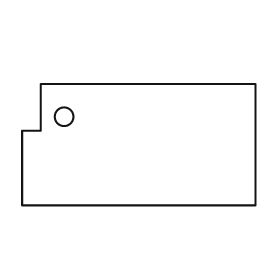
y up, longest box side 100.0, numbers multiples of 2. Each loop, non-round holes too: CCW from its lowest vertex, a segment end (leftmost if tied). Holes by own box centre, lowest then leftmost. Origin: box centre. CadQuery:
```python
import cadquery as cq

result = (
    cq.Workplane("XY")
    .moveTo(-50.0, -26.0)
    .lineTo(50.0, -26.0)
    .lineTo(50.0, 26.0)
    .lineTo(-42.0, 26.0)
    .lineTo(-42.0, 6.0)
    .lineTo(-50.0, 6.0)
    .close()
    .moveTo(-32.0, 12.0)
    .circle(4.0)
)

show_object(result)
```